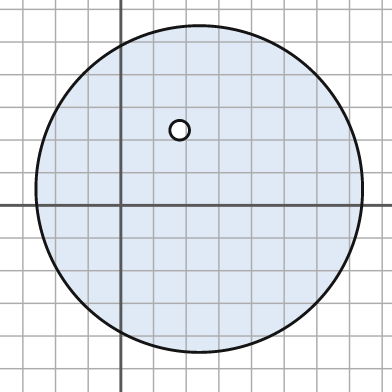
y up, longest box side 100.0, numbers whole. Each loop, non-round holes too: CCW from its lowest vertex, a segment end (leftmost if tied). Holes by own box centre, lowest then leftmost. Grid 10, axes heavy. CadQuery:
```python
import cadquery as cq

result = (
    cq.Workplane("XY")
    .moveTo(24.0, 5.0)
    .circle(50.0)
    .moveTo(18.0, 23.0)
    .circle(3.0)
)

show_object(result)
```